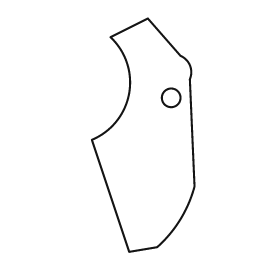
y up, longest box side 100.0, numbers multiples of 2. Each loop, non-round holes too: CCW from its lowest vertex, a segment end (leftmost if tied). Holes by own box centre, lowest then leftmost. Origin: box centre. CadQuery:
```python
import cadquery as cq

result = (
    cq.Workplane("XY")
    .moveTo(-6.0, -50.0)
    .lineTo(6.0, -48.0)
    .threePointArc((16.0, -36.0), (22.0, -22.0))
    .lineTo(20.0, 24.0)
    .threePointArc((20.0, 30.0), (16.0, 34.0))
    .lineTo(2.0, 50.0)
    .lineTo(-14.0, 42.0)
    .threePointArc((-6.0, 18.0), (-22.0, -2.0))
    .close()
    .moveTo(12.0, 16.0)
    .circle(4.0)
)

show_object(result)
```